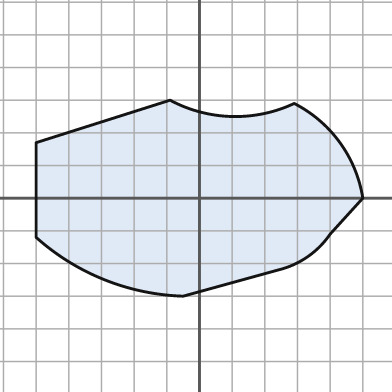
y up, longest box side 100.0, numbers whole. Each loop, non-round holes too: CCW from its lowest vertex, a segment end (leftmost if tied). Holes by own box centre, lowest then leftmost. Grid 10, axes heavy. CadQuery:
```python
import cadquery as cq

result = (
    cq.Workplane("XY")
    .moveTo(-5.0, -30.0)
    .lineTo(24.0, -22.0)
    .threePointArc((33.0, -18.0), (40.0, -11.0))
    .lineTo(50.0, 0.0)
    .threePointArc((43.0, 17.0), (29.0, 29.0))
    .threePointArc((10.0, 25.0), (-9.0, 30.0))
    .lineTo(-50.0, 17.0)
    .lineTo(-50.0, -12.0)
    .threePointArc((-29.0, -25.0), (-5.0, -30.0))
    .close()
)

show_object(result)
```